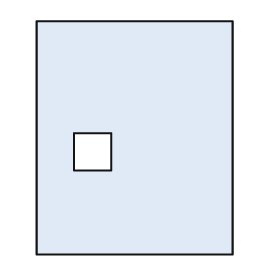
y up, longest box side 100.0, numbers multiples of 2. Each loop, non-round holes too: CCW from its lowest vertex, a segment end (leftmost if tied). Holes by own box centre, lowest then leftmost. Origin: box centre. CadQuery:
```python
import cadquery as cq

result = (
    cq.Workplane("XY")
    .moveTo(-42.0, -50.0)
    .lineTo(42.0, -50.0)
    .lineTo(42.0, 50.0)
    .lineTo(-42.0, 50.0)
    .close()
    .moveTo(-26.0, -14.0)
    .lineTo(-10.0, -14.0)
    .lineTo(-10.0, 2.0)
    .lineTo(-26.0, 2.0)
    .close()
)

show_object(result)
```